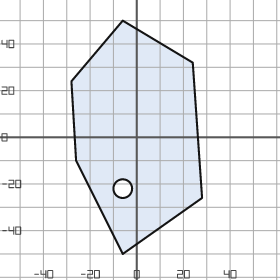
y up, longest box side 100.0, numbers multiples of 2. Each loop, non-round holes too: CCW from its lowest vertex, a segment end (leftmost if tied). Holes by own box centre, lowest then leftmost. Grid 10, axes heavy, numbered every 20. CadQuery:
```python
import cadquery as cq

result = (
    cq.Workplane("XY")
    .moveTo(-6.0, -50.0)
    .lineTo(28.0, -26.0)
    .lineTo(24.0, 32.0)
    .lineTo(-6.0, 50.0)
    .lineTo(-28.0, 24.0)
    .lineTo(-26.0, -10.0)
    .close()
    .moveTo(-6.0, -22.0)
    .circle(4.0)
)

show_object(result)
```